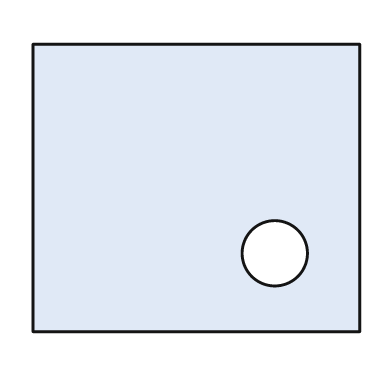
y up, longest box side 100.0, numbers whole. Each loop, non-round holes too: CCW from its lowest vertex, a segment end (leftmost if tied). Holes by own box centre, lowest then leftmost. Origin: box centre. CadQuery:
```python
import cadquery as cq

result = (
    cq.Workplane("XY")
    .moveTo(-50.0, -44.0)
    .lineTo(50.0, -44.0)
    .lineTo(50.0, 44.0)
    .lineTo(-50.0, 44.0)
    .close()
    .moveTo(24.0, -20.0)
    .circle(10.0)
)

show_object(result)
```